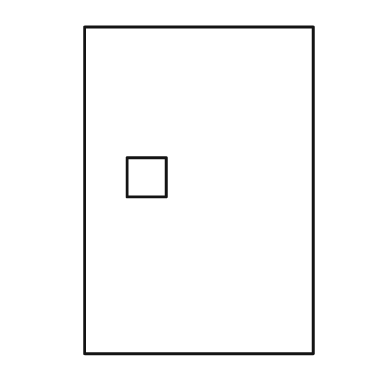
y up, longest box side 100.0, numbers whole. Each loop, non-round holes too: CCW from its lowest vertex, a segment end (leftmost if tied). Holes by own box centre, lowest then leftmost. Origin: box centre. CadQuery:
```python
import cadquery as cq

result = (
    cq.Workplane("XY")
    .moveTo(-35.0, -50.0)
    .lineTo(35.0, -50.0)
    .lineTo(35.0, 50.0)
    .lineTo(-35.0, 50.0)
    .close()
    .moveTo(-22.0, -2.0)
    .lineTo(-10.0, -2.0)
    .lineTo(-10.0, 10.0)
    .lineTo(-22.0, 10.0)
    .close()
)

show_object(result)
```